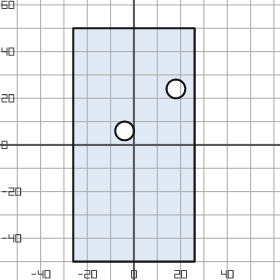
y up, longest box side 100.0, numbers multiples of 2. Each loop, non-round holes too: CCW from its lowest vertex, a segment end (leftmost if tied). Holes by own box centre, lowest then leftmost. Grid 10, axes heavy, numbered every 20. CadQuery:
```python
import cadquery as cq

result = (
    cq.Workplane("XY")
    .moveTo(-26.0, -50.0)
    .lineTo(26.0, -50.0)
    .lineTo(26.0, 50.0)
    .lineTo(-26.0, 50.0)
    .close()
    .moveTo(-4.0, 6.0)
    .circle(4.0)
    .moveTo(18.0, 24.0)
    .circle(4.0)
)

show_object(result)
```